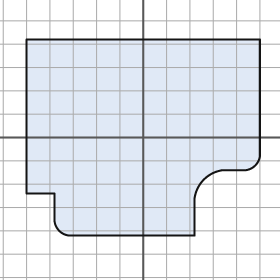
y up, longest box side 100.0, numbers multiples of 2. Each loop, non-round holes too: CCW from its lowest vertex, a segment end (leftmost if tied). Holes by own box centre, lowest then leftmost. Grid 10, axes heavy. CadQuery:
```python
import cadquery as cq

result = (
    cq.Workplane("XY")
    .moveTo(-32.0, -42.0)
    .lineTo(22.0, -42.0)
    .lineTo(22.0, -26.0)
    .threePointArc((26.0, -18.0), (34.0, -14.0))
    .lineTo(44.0, -14.0)
    .threePointArc((48.0, -12.0), (50.0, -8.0))
    .lineTo(50.0, 42.0)
    .lineTo(-50.0, 42.0)
    .lineTo(-50.0, -24.0)
    .lineTo(-38.0, -24.0)
    .lineTo(-38.0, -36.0)
    .threePointArc((-36.0, -40.0), (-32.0, -42.0))
    .close()
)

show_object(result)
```